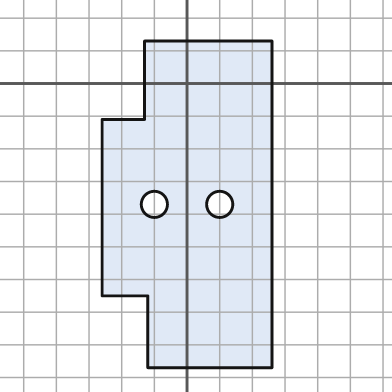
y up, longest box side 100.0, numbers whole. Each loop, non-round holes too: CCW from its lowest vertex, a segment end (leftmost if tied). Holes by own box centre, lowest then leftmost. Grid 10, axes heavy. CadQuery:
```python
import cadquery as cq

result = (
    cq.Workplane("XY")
    .moveTo(-12.0, -87.0)
    .lineTo(26.0, -87.0)
    .lineTo(26.0, 13.0)
    .lineTo(-13.0, 13.0)
    .lineTo(-13.0, -11.0)
    .lineTo(-26.0, -11.0)
    .lineTo(-26.0, -65.0)
    .lineTo(-12.0, -65.0)
    .close()
    .moveTo(-10.0, -37.0)
    .circle(4.0)
    .moveTo(10.0, -37.0)
    .circle(4.0)
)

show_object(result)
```